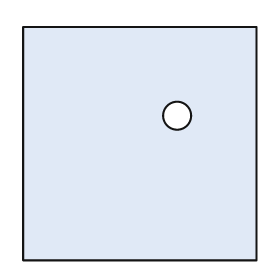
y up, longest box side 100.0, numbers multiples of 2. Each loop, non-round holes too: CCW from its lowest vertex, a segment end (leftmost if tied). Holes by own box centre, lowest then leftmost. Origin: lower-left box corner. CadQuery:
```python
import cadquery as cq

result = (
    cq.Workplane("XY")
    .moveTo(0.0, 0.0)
    .lineTo(100.0, 0.0)
    .lineTo(100.0, 100.0)
    .lineTo(0.0, 100.0)
    .close()
    .moveTo(66.0, 62.0)
    .circle(6.0)
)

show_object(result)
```